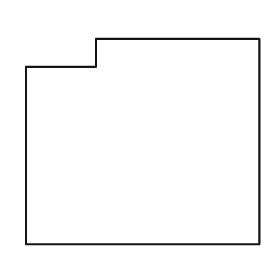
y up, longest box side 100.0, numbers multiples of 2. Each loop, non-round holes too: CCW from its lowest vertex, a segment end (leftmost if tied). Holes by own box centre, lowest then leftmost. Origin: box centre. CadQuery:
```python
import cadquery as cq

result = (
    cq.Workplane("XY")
    .moveTo(-50.0, -44.0)
    .lineTo(50.0, -44.0)
    .lineTo(50.0, 44.0)
    .lineTo(-20.0, 44.0)
    .lineTo(-20.0, 32.0)
    .lineTo(-50.0, 32.0)
    .close()
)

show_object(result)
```